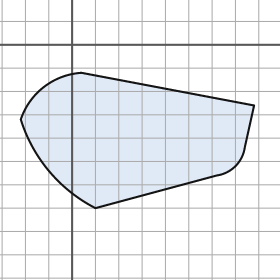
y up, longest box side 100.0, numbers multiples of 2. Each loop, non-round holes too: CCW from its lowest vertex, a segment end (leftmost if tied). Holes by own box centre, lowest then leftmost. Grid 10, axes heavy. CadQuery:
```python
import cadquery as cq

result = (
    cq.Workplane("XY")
    .moveTo(10.0, -70.0)
    .lineTo(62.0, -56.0)
    .threePointArc((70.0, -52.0), (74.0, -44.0))
    .lineTo(78.0, -26.0)
    .lineTo(4.0, -12.0)
    .threePointArc((-12.0, -18.0), (-22.0, -32.0))
    .threePointArc((-10.0, -54.0), (10.0, -70.0))
    .close()
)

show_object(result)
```